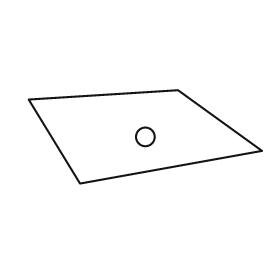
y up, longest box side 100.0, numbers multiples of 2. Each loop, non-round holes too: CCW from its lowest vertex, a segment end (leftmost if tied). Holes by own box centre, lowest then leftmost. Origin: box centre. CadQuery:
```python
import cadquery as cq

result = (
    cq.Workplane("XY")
    .moveTo(-28.0, -20.0)
    .lineTo(50.0, -6.0)
    .lineTo(14.0, 20.0)
    .lineTo(-50.0, 16.0)
    .close()
    .moveTo(0.0, 0.0)
    .circle(4.0)
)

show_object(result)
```